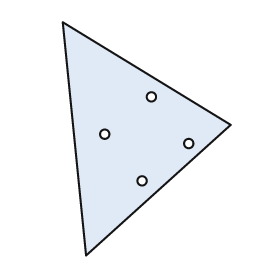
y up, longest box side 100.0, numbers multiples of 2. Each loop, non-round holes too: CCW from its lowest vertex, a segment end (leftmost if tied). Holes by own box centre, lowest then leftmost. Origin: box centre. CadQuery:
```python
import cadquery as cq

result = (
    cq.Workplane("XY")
    .moveTo(-26.0, -50.0)
    .lineTo(36.0, 6.0)
    .lineTo(-36.0, 50.0)
    .close()
    .moveTo(-2.0, -18.0)
    .circle(2.0)
    .moveTo(18.0, -2.0)
    .circle(2.0)
    .moveTo(-18.0, 2.0)
    .circle(2.0)
    .moveTo(2.0, 18.0)
    .circle(2.0)
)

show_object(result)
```